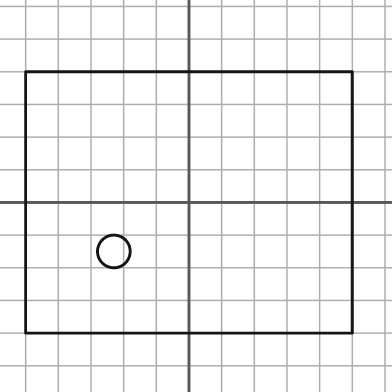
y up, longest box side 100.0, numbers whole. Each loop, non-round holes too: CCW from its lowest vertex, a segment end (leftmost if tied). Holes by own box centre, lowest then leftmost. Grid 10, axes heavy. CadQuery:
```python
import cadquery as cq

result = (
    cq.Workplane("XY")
    .moveTo(-50.0, -40.0)
    .lineTo(50.0, -40.0)
    .lineTo(50.0, 40.0)
    .lineTo(-50.0, 40.0)
    .close()
    .moveTo(-23.0, -15.0)
    .circle(5.0)
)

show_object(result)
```